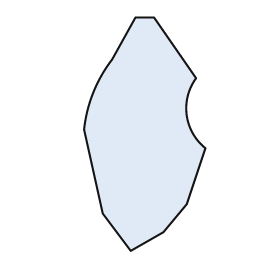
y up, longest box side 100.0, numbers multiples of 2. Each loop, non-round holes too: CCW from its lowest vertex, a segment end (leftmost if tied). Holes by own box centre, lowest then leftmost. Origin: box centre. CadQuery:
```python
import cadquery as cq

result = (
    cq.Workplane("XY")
    .moveTo(-6.0, -50.0)
    .lineTo(8.0, -42.0)
    .lineTo(18.0, -30.0)
    .lineTo(26.0, -6.0)
    .threePointArc((18.0, 8.0), (22.0, 24.0))
    .lineTo(4.0, 50.0)
    .lineTo(-4.0, 50.0)
    .lineTo(-14.0, 32.0)
    .threePointArc((-22.0, 18.0), (-26.0, 2.0))
    .lineTo(-18.0, -34.0)
    .close()
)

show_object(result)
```